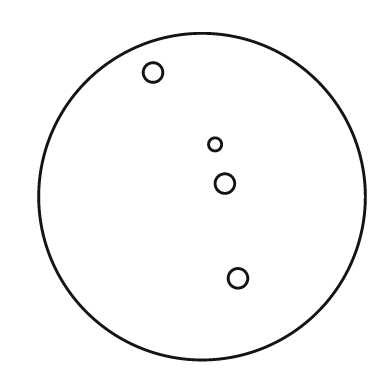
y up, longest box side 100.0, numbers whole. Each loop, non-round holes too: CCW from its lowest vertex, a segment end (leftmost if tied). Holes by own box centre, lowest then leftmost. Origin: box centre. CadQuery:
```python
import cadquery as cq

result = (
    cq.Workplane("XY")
    .moveTo(0.0, 0.0)
    .circle(50.0)
    .moveTo(11.0, -25.0)
    .circle(3.0)
    .moveTo(7.0, 4.0)
    .circle(3.0)
    .moveTo(4.0, 16.0)
    .circle(2.0)
    .moveTo(-15.0, 38.0)
    .circle(3.0)
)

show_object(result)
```